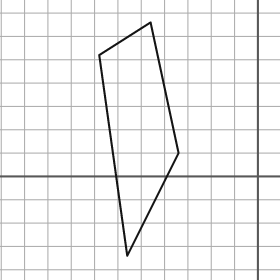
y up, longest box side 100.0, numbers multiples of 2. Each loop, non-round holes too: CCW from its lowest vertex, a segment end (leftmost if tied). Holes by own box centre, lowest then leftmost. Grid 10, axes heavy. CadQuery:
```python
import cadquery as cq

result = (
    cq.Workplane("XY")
    .moveTo(-56.0, -34.0)
    .lineTo(-34.0, 10.0)
    .lineTo(-46.0, 66.0)
    .lineTo(-68.0, 52.0)
    .close()
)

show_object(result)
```